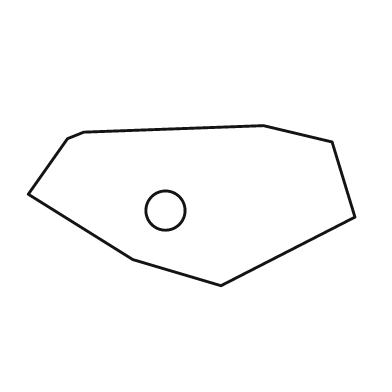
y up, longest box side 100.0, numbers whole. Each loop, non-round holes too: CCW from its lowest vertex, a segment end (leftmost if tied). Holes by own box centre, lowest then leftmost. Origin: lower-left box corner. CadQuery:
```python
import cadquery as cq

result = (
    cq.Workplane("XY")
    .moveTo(59.0, 0.0)
    .lineTo(100.0, 21.0)
    .lineTo(93.0, 44.0)
    .lineTo(72.0, 49.0)
    .lineTo(17.0, 47.0)
    .lineTo(12.0, 45.0)
    .lineTo(0.0, 28.0)
    .lineTo(32.0, 8.0)
    .close()
    .moveTo(42.0, 23.0)
    .circle(6.0)
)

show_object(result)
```